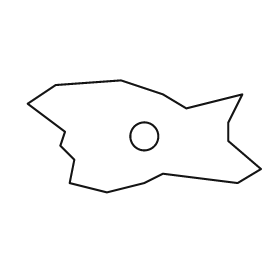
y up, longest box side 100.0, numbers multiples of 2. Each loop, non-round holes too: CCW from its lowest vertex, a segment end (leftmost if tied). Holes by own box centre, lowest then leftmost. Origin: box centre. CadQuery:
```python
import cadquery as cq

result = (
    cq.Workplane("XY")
    .moveTo(-16.0, -24.0)
    .lineTo(0.0, -20.0)
    .lineTo(8.0, -16.0)
    .lineTo(40.0, -20.0)
    .lineTo(50.0, -14.0)
    .lineTo(36.0, -2.0)
    .lineTo(36.0, 6.0)
    .lineTo(42.0, 18.0)
    .lineTo(18.0, 12.0)
    .lineTo(8.0, 18.0)
    .lineTo(-10.0, 24.0)
    .lineTo(-38.0, 22.0)
    .lineTo(-50.0, 14.0)
    .lineTo(-34.0, 2.0)
    .lineTo(-36.0, -4.0)
    .lineTo(-30.0, -10.0)
    .lineTo(-32.0, -20.0)
    .close()
    .moveTo(0.0, 0.0)
    .circle(6.0)
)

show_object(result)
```